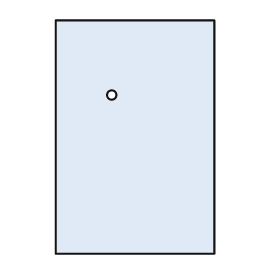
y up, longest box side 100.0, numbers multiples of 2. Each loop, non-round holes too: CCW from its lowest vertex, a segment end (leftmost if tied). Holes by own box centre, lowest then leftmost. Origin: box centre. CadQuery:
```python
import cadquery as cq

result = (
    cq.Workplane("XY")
    .moveTo(-34.0, -50.0)
    .lineTo(34.0, -50.0)
    .lineTo(34.0, 50.0)
    .lineTo(-34.0, 50.0)
    .close()
    .moveTo(-10.0, 18.0)
    .circle(2.0)
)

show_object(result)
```